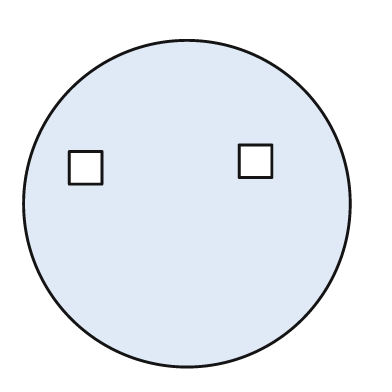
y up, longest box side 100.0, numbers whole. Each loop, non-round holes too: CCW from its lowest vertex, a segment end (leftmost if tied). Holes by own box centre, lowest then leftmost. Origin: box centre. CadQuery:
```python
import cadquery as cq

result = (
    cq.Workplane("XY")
    .moveTo(0.0, 0.0)
    .circle(50.0)
    .moveTo(-36.0, 6.0)
    .lineTo(-26.0, 6.0)
    .lineTo(-26.0, 16.0)
    .lineTo(-36.0, 16.0)
    .close()
    .moveTo(16.0, 8.0)
    .lineTo(26.0, 8.0)
    .lineTo(26.0, 18.0)
    .lineTo(16.0, 18.0)
    .close()
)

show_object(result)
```